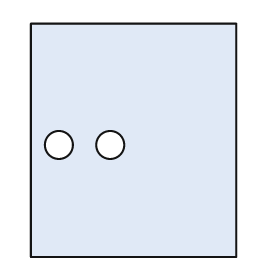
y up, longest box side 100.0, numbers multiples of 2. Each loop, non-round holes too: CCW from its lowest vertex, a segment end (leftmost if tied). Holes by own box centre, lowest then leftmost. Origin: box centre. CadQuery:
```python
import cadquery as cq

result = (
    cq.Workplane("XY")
    .moveTo(-44.0, -50.0)
    .lineTo(44.0, -50.0)
    .lineTo(44.0, 50.0)
    .lineTo(-44.0, 50.0)
    .close()
    .moveTo(-32.0, -2.0)
    .circle(6.0)
    .moveTo(-10.0, -2.0)
    .circle(6.0)
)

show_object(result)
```